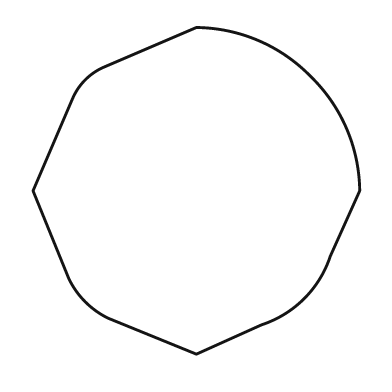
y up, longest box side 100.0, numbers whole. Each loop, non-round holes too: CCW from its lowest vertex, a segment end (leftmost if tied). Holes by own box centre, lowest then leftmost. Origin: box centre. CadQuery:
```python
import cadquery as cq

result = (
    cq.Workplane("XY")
    .moveTo(0.0, -50.0)
    .lineTo(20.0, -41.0)
    .threePointArc((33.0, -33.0), (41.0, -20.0))
    .lineTo(50.0, 0.0)
    .threePointArc((46.0, 19.0), (35.0, 35.0))
    .threePointArc((19.0, 46.0), (0.0, 50.0))
    .lineTo(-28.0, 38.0)
    .threePointArc((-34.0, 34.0), (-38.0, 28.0))
    .lineTo(-50.0, 0.0)
    .lineTo(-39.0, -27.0)
    .threePointArc((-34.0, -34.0), (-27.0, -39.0))
    .close()
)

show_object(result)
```